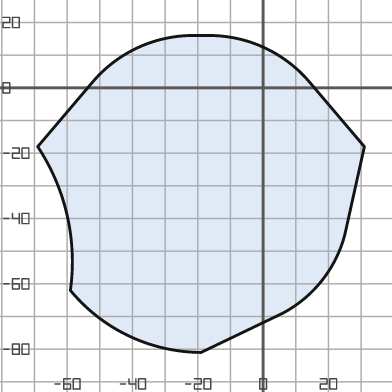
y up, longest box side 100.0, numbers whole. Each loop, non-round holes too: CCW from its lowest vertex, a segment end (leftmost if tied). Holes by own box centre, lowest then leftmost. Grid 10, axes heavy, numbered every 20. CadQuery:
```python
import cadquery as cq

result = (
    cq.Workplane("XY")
    .moveTo(-19.0, -81.0)
    .lineTo(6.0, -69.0)
    .threePointArc((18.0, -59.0), (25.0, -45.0))
    .lineTo(31.0, -18.0)
    .lineTo(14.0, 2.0)
    .threePointArc((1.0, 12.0), (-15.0, 16.0))
    .lineTo(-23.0, 16.0)
    .threePointArc((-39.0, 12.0), (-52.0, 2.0))
    .lineTo(-69.0, -18.0)
    .threePointArc((-60.0, -39.0), (-59.0, -62.0))
    .threePointArc((-41.0, -76.0), (-19.0, -81.0))
    .close()
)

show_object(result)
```